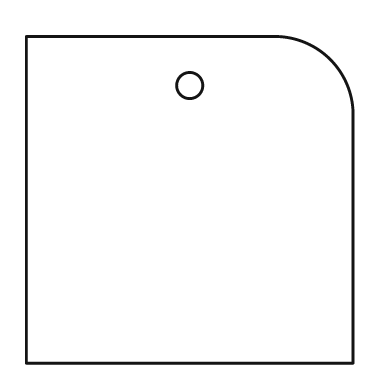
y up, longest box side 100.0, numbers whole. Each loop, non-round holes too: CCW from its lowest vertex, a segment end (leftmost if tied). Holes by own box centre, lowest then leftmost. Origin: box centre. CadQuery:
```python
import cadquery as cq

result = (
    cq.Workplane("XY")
    .moveTo(-50.0, -50.0)
    .lineTo(50.0, -50.0)
    .lineTo(50.0, 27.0)
    .threePointArc((43.0, 43.0), (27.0, 50.0))
    .lineTo(-50.0, 50.0)
    .close()
    .moveTo(0.0, 35.0)
    .circle(4.0)
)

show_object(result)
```